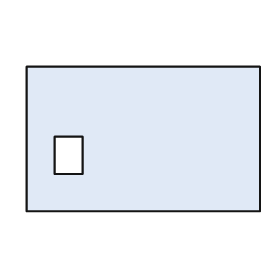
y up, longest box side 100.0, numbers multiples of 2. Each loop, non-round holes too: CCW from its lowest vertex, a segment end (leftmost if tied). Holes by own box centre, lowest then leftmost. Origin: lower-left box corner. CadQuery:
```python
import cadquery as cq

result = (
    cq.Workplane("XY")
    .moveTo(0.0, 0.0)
    .lineTo(100.0, 0.0)
    .lineTo(100.0, 62.0)
    .lineTo(0.0, 62.0)
    .close()
    .moveTo(12.0, 16.0)
    .lineTo(24.0, 16.0)
    .lineTo(24.0, 32.0)
    .lineTo(12.0, 32.0)
    .close()
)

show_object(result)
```